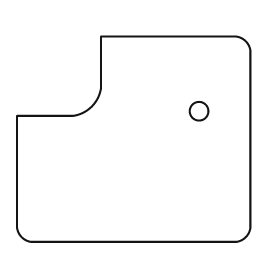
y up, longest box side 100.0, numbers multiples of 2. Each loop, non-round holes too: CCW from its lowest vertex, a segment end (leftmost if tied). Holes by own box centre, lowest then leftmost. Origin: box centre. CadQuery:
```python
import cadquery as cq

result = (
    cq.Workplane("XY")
    .moveTo(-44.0, -44.0)
    .lineTo(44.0, -44.0)
    .threePointArc((48.0, -42.0), (50.0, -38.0))
    .lineTo(50.0, 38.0)
    .threePointArc((48.0, 42.0), (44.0, 44.0))
    .lineTo(-14.0, 44.0)
    .lineTo(-14.0, 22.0)
    .threePointArc((-18.0, 14.0), (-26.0, 10.0))
    .lineTo(-50.0, 10.0)
    .lineTo(-50.0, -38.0)
    .threePointArc((-48.0, -42.0), (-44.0, -44.0))
    .close()
    .moveTo(28.0, 12.0)
    .circle(4.0)
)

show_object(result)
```